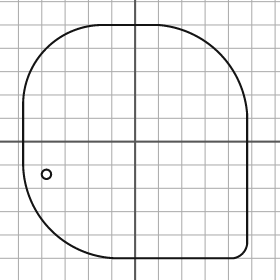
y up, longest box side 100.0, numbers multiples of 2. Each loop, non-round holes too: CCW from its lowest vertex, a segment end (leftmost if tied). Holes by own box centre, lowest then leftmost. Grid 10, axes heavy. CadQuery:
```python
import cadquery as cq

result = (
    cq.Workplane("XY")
    .moveTo(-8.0, -50.0)
    .lineTo(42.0, -50.0)
    .threePointArc((46.0, -48.0), (48.0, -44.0))
    .lineTo(48.0, 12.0)
    .threePointArc((36.0, 38.0), (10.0, 50.0))
    .lineTo(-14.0, 50.0)
    .threePointArc((-38.0, 40.0), (-48.0, 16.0))
    .lineTo(-48.0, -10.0)
    .threePointArc((-36.0, -38.0), (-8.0, -50.0))
    .close()
    .moveTo(-38.0, -14.0)
    .circle(2.0)
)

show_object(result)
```